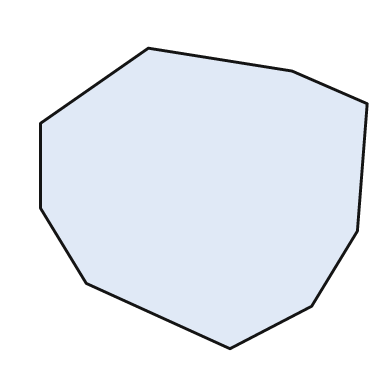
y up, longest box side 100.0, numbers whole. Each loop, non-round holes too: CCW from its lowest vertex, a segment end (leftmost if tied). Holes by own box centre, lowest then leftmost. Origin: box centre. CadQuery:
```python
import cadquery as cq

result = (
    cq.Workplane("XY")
    .moveTo(8.0, -46.0)
    .lineTo(33.0, -33.0)
    .lineTo(47.0, -10.0)
    .lineTo(50.0, 29.0)
    .lineTo(27.0, 39.0)
    .lineTo(-17.0, 46.0)
    .lineTo(-50.0, 23.0)
    .lineTo(-50.0, -3.0)
    .lineTo(-36.0, -26.0)
    .close()
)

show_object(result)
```